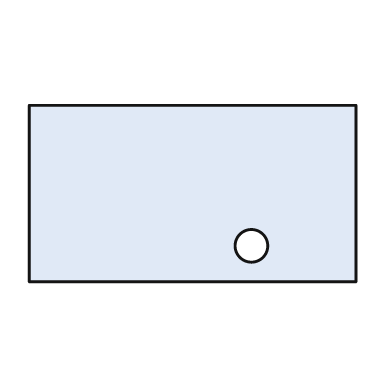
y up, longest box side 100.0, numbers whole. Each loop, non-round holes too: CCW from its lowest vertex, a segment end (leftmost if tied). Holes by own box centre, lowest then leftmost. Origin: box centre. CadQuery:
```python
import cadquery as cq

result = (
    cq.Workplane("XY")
    .moveTo(-50.0, -27.0)
    .lineTo(50.0, -27.0)
    .lineTo(50.0, 27.0)
    .lineTo(-50.0, 27.0)
    .close()
    .moveTo(18.0, -16.0)
    .circle(5.0)
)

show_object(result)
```